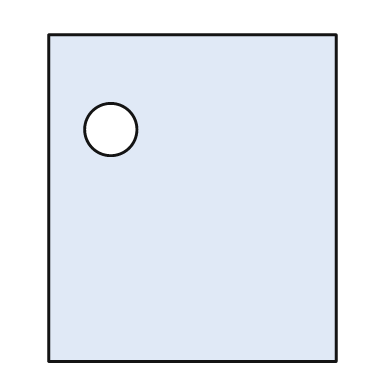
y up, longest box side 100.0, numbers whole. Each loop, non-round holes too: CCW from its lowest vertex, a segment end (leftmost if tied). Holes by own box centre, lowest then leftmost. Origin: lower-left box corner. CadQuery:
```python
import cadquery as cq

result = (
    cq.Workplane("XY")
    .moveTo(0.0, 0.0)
    .lineTo(88.0, 0.0)
    .lineTo(88.0, 100.0)
    .lineTo(0.0, 100.0)
    .close()
    .moveTo(19.0, 71.0)
    .circle(8.0)
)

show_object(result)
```